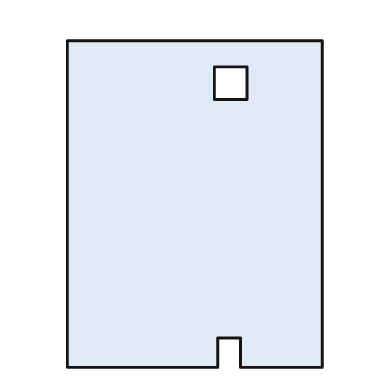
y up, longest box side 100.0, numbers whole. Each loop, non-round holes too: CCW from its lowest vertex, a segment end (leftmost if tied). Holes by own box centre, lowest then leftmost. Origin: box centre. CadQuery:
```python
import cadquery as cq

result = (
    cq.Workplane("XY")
    .moveTo(-39.0, -50.0)
    .lineTo(7.0, -50.0)
    .lineTo(7.0, -41.0)
    .lineTo(14.0, -41.0)
    .lineTo(14.0, -50.0)
    .lineTo(39.0, -50.0)
    .lineTo(39.0, 50.0)
    .lineTo(-39.0, 50.0)
    .close()
    .moveTo(6.0, 32.0)
    .lineTo(16.0, 32.0)
    .lineTo(16.0, 42.0)
    .lineTo(6.0, 42.0)
    .close()
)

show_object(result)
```